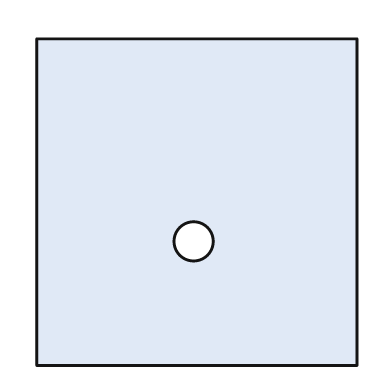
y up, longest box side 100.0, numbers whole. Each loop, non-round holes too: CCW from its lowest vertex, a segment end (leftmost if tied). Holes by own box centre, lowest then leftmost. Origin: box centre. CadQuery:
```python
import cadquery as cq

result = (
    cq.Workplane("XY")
    .moveTo(-49.0, -50.0)
    .lineTo(49.0, -50.0)
    .lineTo(49.0, 50.0)
    .lineTo(-49.0, 50.0)
    .close()
    .moveTo(-1.0, -12.0)
    .circle(6.0)
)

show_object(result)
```